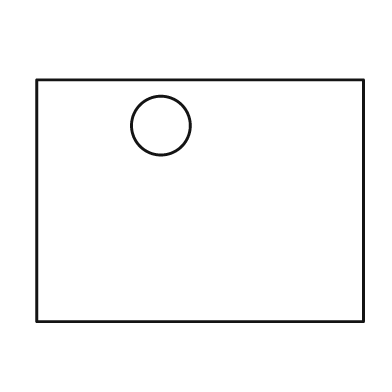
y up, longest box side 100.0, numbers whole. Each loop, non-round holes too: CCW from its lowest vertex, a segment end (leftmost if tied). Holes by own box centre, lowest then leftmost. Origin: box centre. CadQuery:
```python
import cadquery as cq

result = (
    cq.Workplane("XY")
    .moveTo(-50.0, -37.0)
    .lineTo(50.0, -37.0)
    .lineTo(50.0, 37.0)
    .lineTo(-50.0, 37.0)
    .close()
    .moveTo(-12.0, 23.0)
    .circle(9.0)
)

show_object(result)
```